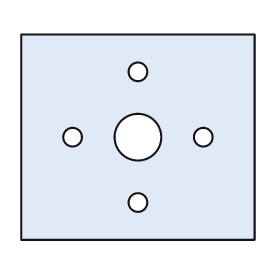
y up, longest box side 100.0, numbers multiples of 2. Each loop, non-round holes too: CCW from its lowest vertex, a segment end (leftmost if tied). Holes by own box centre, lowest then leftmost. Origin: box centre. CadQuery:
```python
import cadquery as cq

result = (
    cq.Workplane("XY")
    .moveTo(-50.0, -44.0)
    .lineTo(50.0, -44.0)
    .lineTo(50.0, 44.0)
    .lineTo(-50.0, 44.0)
    .close()
    .moveTo(0.0, -28.0)
    .circle(4.0)
    .moveTo(-28.0, 0.0)
    .circle(4.0)
    .moveTo(0.0, 0.0)
    .circle(10.0)
    .moveTo(28.0, 0.0)
    .circle(4.0)
    .moveTo(0.0, 28.0)
    .circle(4.0)
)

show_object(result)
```